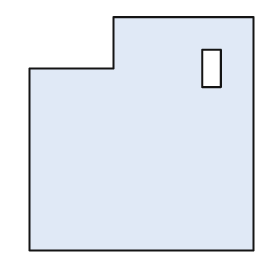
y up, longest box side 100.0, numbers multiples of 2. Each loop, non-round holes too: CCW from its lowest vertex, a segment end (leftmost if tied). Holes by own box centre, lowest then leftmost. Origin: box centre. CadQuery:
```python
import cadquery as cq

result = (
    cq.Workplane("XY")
    .moveTo(-48.0, -50.0)
    .lineTo(48.0, -50.0)
    .lineTo(48.0, 50.0)
    .lineTo(-12.0, 50.0)
    .lineTo(-12.0, 28.0)
    .lineTo(-48.0, 28.0)
    .close()
    .moveTo(26.0, 20.0)
    .lineTo(34.0, 20.0)
    .lineTo(34.0, 36.0)
    .lineTo(26.0, 36.0)
    .close()
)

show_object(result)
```